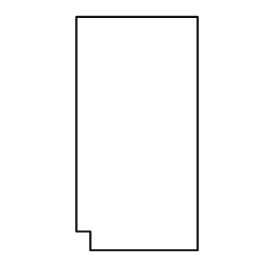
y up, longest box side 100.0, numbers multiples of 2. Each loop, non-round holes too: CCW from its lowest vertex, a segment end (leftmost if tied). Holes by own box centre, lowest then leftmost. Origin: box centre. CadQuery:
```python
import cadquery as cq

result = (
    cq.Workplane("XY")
    .moveTo(-20.0, -50.0)
    .lineTo(26.0, -50.0)
    .lineTo(26.0, 50.0)
    .lineTo(-26.0, 50.0)
    .lineTo(-26.0, -42.0)
    .lineTo(-20.0, -42.0)
    .close()
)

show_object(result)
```